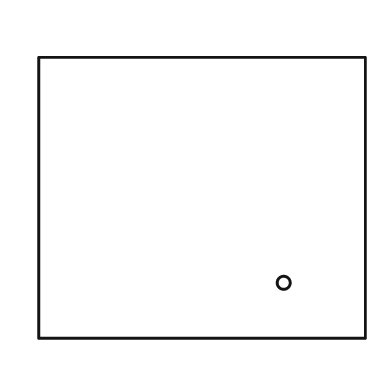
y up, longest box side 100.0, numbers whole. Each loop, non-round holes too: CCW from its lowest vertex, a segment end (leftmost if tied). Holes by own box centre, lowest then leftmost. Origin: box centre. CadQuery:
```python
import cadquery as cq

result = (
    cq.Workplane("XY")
    .moveTo(-50.0, -43.0)
    .lineTo(50.0, -43.0)
    .lineTo(50.0, 43.0)
    .lineTo(-50.0, 43.0)
    .close()
    .moveTo(25.0, -26.0)
    .circle(2.0)
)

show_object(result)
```